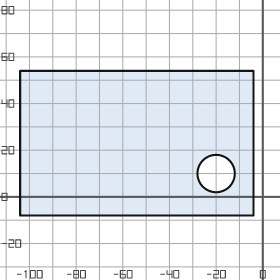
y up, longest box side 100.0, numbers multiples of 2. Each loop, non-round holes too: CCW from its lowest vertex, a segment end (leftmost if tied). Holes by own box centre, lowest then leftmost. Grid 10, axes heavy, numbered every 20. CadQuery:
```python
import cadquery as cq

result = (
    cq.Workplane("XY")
    .moveTo(-104.0, -8.0)
    .lineTo(-4.0, -8.0)
    .lineTo(-4.0, 54.0)
    .lineTo(-104.0, 54.0)
    .close()
    .moveTo(-20.0, 10.0)
    .circle(8.0)
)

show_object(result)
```